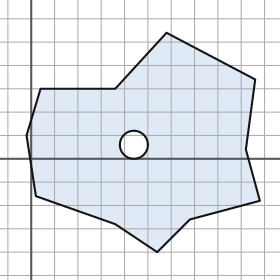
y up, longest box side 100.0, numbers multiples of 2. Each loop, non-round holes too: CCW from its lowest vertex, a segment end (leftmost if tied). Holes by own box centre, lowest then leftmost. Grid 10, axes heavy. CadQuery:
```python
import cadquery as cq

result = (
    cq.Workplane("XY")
    .moveTo(54.0, -40.0)
    .lineTo(68.0, -26.0)
    .lineTo(98.0, -18.0)
    .lineTo(92.0, 4.0)
    .lineTo(96.0, 34.0)
    .lineTo(58.0, 54.0)
    .lineTo(36.0, 30.0)
    .lineTo(4.0, 30.0)
    .lineTo(-2.0, 10.0)
    .lineTo(2.0, -16.0)
    .lineTo(36.0, -28.0)
    .close()
    .moveTo(44.0, 6.0)
    .circle(6.0)
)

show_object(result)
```